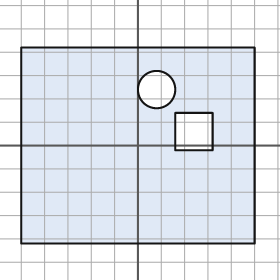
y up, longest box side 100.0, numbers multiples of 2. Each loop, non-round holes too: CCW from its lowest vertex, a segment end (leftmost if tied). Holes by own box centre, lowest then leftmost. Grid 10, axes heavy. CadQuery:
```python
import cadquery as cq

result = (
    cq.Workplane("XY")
    .moveTo(-50.0, -42.0)
    .lineTo(50.0, -42.0)
    .lineTo(50.0, 42.0)
    .lineTo(-50.0, 42.0)
    .close()
    .moveTo(16.0, -2.0)
    .lineTo(32.0, -2.0)
    .lineTo(32.0, 14.0)
    .lineTo(16.0, 14.0)
    .close()
    .moveTo(8.0, 24.0)
    .circle(8.0)
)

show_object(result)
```